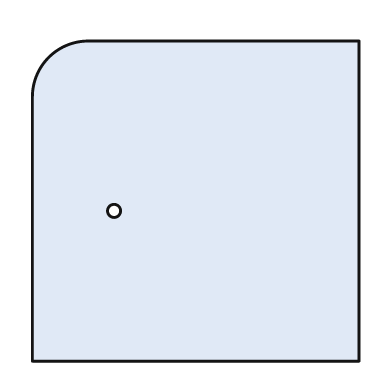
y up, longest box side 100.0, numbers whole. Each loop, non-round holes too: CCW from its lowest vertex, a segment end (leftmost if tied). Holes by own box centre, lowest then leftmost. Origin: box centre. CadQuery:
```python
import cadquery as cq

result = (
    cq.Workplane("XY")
    .moveTo(-50.0, -49.0)
    .lineTo(50.0, -49.0)
    .lineTo(50.0, 49.0)
    .lineTo(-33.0, 49.0)
    .threePointArc((-45.0, 44.0), (-50.0, 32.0))
    .close()
    .moveTo(-25.0, -3.0)
    .circle(2.0)
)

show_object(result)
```